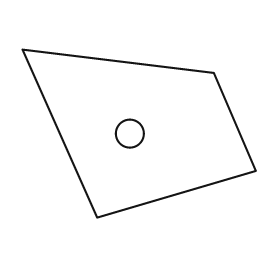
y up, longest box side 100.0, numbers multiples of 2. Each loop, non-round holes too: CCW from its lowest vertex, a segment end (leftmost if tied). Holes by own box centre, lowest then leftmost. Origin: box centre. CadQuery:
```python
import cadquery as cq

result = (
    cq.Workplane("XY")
    .moveTo(-18.0, -36.0)
    .lineTo(50.0, -16.0)
    .lineTo(32.0, 26.0)
    .lineTo(-50.0, 36.0)
    .close()
    .moveTo(-4.0, 0.0)
    .circle(6.0)
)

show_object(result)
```